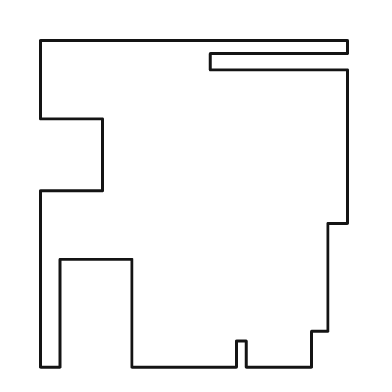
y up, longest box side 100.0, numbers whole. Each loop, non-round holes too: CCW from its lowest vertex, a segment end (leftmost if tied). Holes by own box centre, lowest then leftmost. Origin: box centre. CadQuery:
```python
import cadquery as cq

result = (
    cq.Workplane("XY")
    .moveTo(-47.0, -50.0)
    .lineTo(-41.0, -50.0)
    .lineTo(-41.0, -17.0)
    .lineTo(-19.0, -17.0)
    .lineTo(-19.0, -50.0)
    .lineTo(13.0, -50.0)
    .lineTo(13.0, -42.0)
    .lineTo(16.0, -42.0)
    .lineTo(16.0, -50.0)
    .lineTo(36.0, -50.0)
    .lineTo(36.0, -39.0)
    .lineTo(41.0, -39.0)
    .lineTo(41.0, -6.0)
    .lineTo(47.0, -6.0)
    .lineTo(47.0, 41.0)
    .lineTo(5.0, 41.0)
    .lineTo(5.0, 46.0)
    .lineTo(47.0, 46.0)
    .lineTo(47.0, 50.0)
    .lineTo(-47.0, 50.0)
    .lineTo(-47.0, 26.0)
    .lineTo(-28.0, 26.0)
    .lineTo(-28.0, 4.0)
    .lineTo(-47.0, 4.0)
    .close()
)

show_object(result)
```